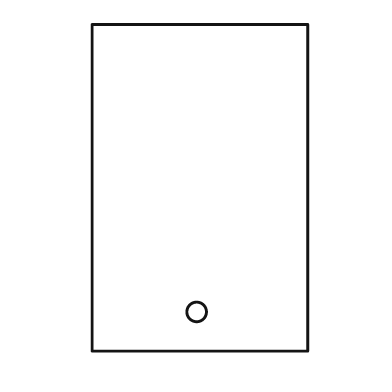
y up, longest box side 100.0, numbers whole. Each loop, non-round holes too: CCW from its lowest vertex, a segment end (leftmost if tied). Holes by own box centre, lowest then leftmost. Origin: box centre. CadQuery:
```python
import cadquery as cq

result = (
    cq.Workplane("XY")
    .moveTo(-33.0, -50.0)
    .lineTo(33.0, -50.0)
    .lineTo(33.0, 50.0)
    .lineTo(-33.0, 50.0)
    .close()
    .moveTo(-1.0, -38.0)
    .circle(3.0)
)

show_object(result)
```